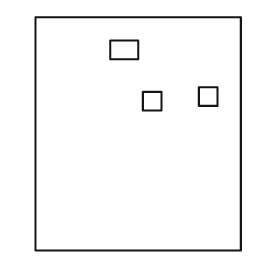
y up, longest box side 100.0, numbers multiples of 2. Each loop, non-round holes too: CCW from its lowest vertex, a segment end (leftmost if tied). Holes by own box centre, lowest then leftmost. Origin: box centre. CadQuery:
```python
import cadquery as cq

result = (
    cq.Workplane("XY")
    .moveTo(-44.0, -50.0)
    .lineTo(44.0, -50.0)
    .lineTo(44.0, 50.0)
    .lineTo(-44.0, 50.0)
    .close()
    .moveTo(2.0, 10.0)
    .lineTo(10.0, 10.0)
    .lineTo(10.0, 18.0)
    .lineTo(2.0, 18.0)
    .close()
    .moveTo(26.0, 12.0)
    .lineTo(34.0, 12.0)
    .lineTo(34.0, 20.0)
    .lineTo(26.0, 20.0)
    .close()
    .moveTo(-12.0, 32.0)
    .lineTo(0.0, 32.0)
    .lineTo(0.0, 40.0)
    .lineTo(-12.0, 40.0)
    .close()
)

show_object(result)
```